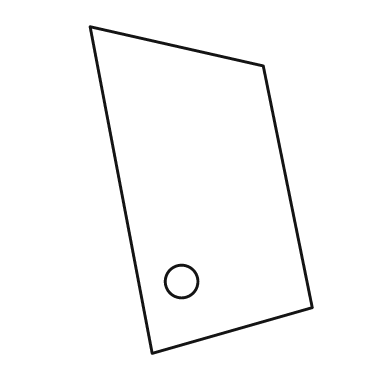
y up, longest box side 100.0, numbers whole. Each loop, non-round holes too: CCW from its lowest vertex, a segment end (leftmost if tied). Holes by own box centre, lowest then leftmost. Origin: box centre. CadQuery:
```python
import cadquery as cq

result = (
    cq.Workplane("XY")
    .moveTo(-15.0, -50.0)
    .lineTo(34.0, -36.0)
    .lineTo(19.0, 38.0)
    .lineTo(-34.0, 50.0)
    .close()
    .moveTo(-6.0, -28.0)
    .circle(5.0)
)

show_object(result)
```